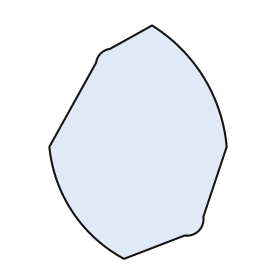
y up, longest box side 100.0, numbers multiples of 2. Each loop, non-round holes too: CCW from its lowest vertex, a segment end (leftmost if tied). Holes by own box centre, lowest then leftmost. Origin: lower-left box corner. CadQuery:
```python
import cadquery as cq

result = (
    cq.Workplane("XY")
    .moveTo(32.0, 0.0)
    .lineTo(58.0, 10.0)
    .threePointArc((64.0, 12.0), (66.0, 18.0))
    .lineTo(76.0, 48.0)
    .threePointArc((66.0, 78.0), (44.0, 100.0))
    .lineTo(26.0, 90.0)
    .threePointArc((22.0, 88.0), (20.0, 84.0))
    .lineTo(0.0, 48.0)
    .threePointArc((10.0, 20.0), (32.0, 0.0))
    .close()
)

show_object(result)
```